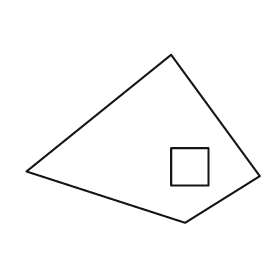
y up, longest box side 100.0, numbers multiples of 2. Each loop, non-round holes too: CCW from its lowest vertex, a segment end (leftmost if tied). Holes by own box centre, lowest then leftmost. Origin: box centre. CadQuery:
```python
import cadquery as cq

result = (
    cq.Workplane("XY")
    .moveTo(18.0, -36.0)
    .lineTo(50.0, -16.0)
    .lineTo(12.0, 36.0)
    .lineTo(-50.0, -14.0)
    .close()
    .moveTo(12.0, -20.0)
    .lineTo(28.0, -20.0)
    .lineTo(28.0, -4.0)
    .lineTo(12.0, -4.0)
    .close()
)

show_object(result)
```